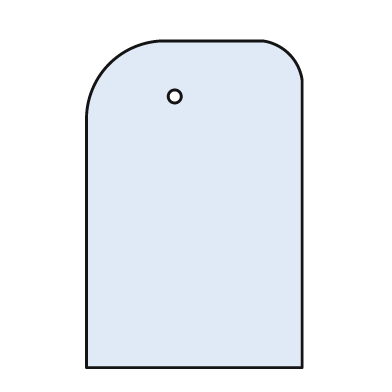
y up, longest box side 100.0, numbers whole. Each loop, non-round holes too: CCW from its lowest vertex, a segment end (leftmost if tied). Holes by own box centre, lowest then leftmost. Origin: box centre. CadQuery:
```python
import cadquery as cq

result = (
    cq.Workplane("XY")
    .moveTo(-33.0, -50.0)
    .lineTo(33.0, -50.0)
    .lineTo(33.0, 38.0)
    .threePointArc((29.0, 46.0), (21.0, 50.0))
    .lineTo(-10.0, 50.0)
    .threePointArc((-26.0, 43.0), (-33.0, 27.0))
    .close()
    .moveTo(-6.0, 33.0)
    .circle(2.0)
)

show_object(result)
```